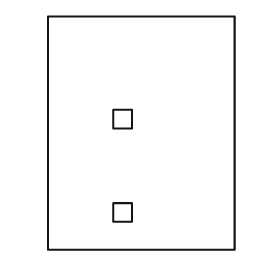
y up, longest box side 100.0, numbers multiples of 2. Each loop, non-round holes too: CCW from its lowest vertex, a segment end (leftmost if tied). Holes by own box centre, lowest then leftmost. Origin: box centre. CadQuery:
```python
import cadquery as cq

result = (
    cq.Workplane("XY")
    .moveTo(-40.0, -50.0)
    .lineTo(40.0, -50.0)
    .lineTo(40.0, 50.0)
    .lineTo(-40.0, 50.0)
    .close()
    .moveTo(-12.0, -38.0)
    .lineTo(-4.0, -38.0)
    .lineTo(-4.0, -30.0)
    .lineTo(-12.0, -30.0)
    .close()
    .moveTo(-12.0, 2.0)
    .lineTo(-4.0, 2.0)
    .lineTo(-4.0, 10.0)
    .lineTo(-12.0, 10.0)
    .close()
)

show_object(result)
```